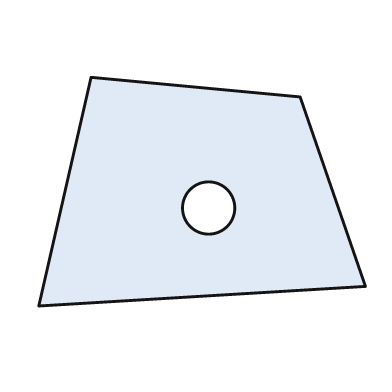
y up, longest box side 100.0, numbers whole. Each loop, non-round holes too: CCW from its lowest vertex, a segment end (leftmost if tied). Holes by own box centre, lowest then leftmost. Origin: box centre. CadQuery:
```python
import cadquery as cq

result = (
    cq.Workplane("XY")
    .moveTo(-50.0, -35.0)
    .lineTo(50.0, -29.0)
    .lineTo(30.0, 29.0)
    .lineTo(-34.0, 35.0)
    .close()
    .moveTo(2.0, -5.0)
    .circle(8.0)
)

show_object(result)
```